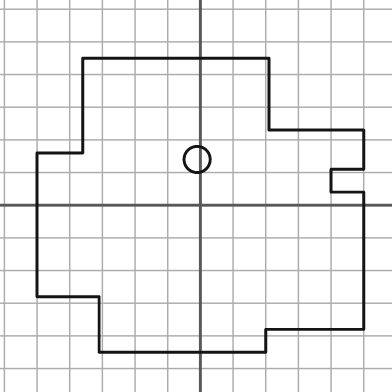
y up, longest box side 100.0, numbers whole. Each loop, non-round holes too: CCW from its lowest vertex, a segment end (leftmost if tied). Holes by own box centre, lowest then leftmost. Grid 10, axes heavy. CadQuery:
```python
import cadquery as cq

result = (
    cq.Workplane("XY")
    .moveTo(-31.0, -45.0)
    .lineTo(20.0, -45.0)
    .lineTo(20.0, -38.0)
    .lineTo(50.0, -38.0)
    .lineTo(50.0, 4.0)
    .lineTo(40.0, 4.0)
    .lineTo(40.0, 11.0)
    .lineTo(50.0, 11.0)
    .lineTo(50.0, 23.0)
    .lineTo(21.0, 23.0)
    .lineTo(21.0, 45.0)
    .lineTo(-36.0, 45.0)
    .lineTo(-36.0, 16.0)
    .lineTo(-50.0, 16.0)
    .lineTo(-50.0, -28.0)
    .lineTo(-31.0, -28.0)
    .close()
    .moveTo(-1.0, 14.0)
    .circle(4.0)
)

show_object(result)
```